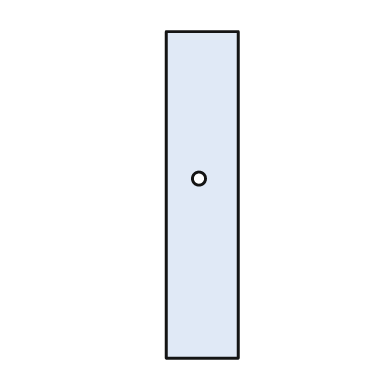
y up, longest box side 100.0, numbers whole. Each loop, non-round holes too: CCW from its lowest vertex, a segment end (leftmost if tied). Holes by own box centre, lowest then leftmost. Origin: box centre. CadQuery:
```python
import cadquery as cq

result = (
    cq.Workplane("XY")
    .moveTo(-11.0, -50.0)
    .lineTo(11.0, -50.0)
    .lineTo(11.0, 50.0)
    .lineTo(-11.0, 50.0)
    .close()
    .moveTo(-1.0, 5.0)
    .circle(2.0)
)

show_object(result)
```